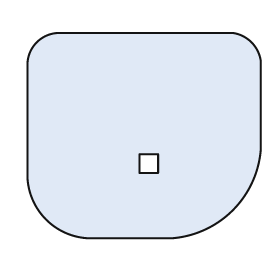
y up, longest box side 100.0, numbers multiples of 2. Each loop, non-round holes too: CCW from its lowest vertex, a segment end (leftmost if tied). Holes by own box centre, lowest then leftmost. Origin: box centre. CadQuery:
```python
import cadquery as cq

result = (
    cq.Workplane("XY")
    .moveTo(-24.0, -44.0)
    .lineTo(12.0, -44.0)
    .threePointArc((38.0, -32.0), (50.0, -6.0))
    .lineTo(50.0, 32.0)
    .threePointArc((46.0, 40.0), (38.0, 44.0))
    .lineTo(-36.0, 44.0)
    .threePointArc((-46.0, 40.0), (-50.0, 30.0))
    .lineTo(-50.0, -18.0)
    .threePointArc((-42.0, -36.0), (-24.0, -44.0))
    .close()
    .moveTo(-2.0, -16.0)
    .lineTo(6.0, -16.0)
    .lineTo(6.0, -8.0)
    .lineTo(-2.0, -8.0)
    .close()
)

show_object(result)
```